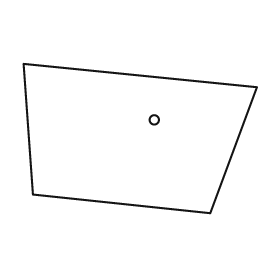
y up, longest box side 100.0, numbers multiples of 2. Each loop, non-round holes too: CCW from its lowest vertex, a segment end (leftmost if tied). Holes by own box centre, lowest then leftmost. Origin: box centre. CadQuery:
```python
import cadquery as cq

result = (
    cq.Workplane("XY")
    .moveTo(30.0, -32.0)
    .lineTo(50.0, 22.0)
    .lineTo(-50.0, 32.0)
    .lineTo(-46.0, -24.0)
    .close()
    .moveTo(6.0, 8.0)
    .circle(2.0)
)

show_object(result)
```